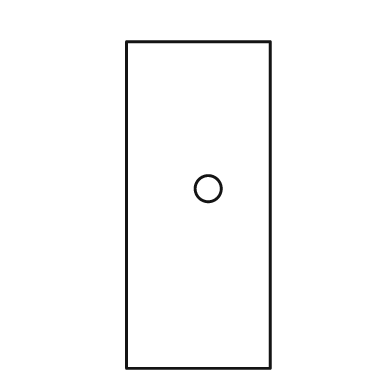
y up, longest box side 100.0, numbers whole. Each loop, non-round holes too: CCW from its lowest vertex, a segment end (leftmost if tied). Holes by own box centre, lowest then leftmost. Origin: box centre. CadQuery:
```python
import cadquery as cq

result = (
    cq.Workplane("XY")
    .moveTo(-22.0, -50.0)
    .lineTo(22.0, -50.0)
    .lineTo(22.0, 50.0)
    .lineTo(-22.0, 50.0)
    .close()
    .moveTo(3.0, 5.0)
    .circle(4.0)
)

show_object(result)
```